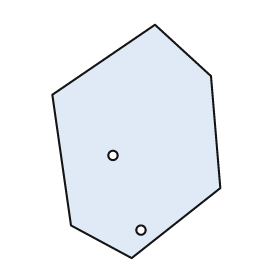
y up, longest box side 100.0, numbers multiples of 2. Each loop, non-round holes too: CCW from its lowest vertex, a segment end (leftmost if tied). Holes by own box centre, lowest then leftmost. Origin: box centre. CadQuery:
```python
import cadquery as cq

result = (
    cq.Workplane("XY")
    .moveTo(-2.0, -50.0)
    .lineTo(36.0, -20.0)
    .lineTo(32.0, 28.0)
    .lineTo(8.0, 50.0)
    .lineTo(-36.0, 20.0)
    .lineTo(-28.0, -36.0)
    .close()
    .moveTo(2.0, -38.0)
    .circle(2.0)
    .moveTo(-10.0, -6.0)
    .circle(2.0)
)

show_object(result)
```